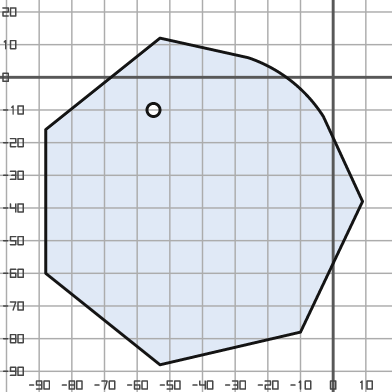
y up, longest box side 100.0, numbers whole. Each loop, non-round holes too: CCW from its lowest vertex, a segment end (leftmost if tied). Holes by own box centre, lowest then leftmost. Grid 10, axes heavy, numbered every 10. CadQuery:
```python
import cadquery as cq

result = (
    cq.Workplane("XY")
    .moveTo(-53.0, -88.0)
    .lineTo(-10.0, -78.0)
    .lineTo(9.0, -38.0)
    .lineTo(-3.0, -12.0)
    .threePointArc((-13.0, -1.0), (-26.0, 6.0))
    .lineTo(-53.0, 12.0)
    .lineTo(-88.0, -16.0)
    .lineTo(-88.0, -60.0)
    .close()
    .moveTo(-55.0, -10.0)
    .circle(2.0)
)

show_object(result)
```